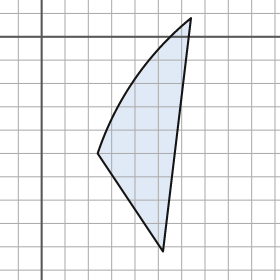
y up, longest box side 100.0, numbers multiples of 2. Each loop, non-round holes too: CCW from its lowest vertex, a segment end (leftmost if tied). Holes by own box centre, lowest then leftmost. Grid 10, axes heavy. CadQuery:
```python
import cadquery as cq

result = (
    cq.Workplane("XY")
    .moveTo(52.0, -92.0)
    .lineTo(64.0, 8.0)
    .threePointArc((40.0, -18.0), (24.0, -50.0))
    .close()
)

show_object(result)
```